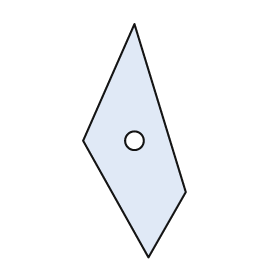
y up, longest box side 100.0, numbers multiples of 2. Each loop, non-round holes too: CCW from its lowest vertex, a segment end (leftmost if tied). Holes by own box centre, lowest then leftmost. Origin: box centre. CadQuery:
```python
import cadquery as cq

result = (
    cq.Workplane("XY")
    .moveTo(6.0, -50.0)
    .lineTo(22.0, -22.0)
    .lineTo(0.0, 50.0)
    .lineTo(-22.0, 0.0)
    .close()
    .moveTo(0.0, 0.0)
    .circle(4.0)
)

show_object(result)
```